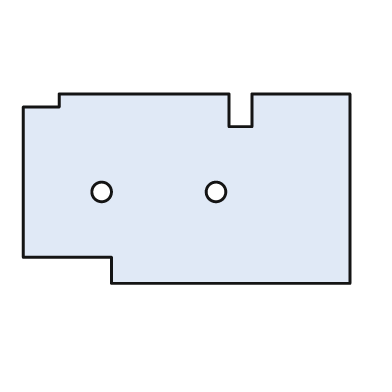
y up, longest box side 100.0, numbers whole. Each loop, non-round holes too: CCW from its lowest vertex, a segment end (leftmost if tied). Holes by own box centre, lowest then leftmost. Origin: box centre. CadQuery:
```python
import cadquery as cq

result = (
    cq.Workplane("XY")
    .moveTo(-23.0, -29.0)
    .lineTo(50.0, -29.0)
    .lineTo(50.0, 29.0)
    .lineTo(20.0, 29.0)
    .lineTo(20.0, 19.0)
    .lineTo(13.0, 19.0)
    .lineTo(13.0, 29.0)
    .lineTo(-39.0, 29.0)
    .lineTo(-39.0, 25.0)
    .lineTo(-50.0, 25.0)
    .lineTo(-50.0, -21.0)
    .lineTo(-23.0, -21.0)
    .close()
    .moveTo(-26.0, -1.0)
    .circle(3.0)
    .moveTo(9.0, -1.0)
    .circle(3.0)
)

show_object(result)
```